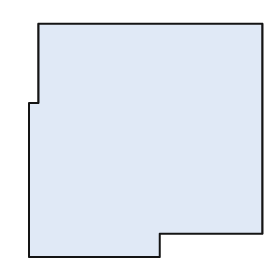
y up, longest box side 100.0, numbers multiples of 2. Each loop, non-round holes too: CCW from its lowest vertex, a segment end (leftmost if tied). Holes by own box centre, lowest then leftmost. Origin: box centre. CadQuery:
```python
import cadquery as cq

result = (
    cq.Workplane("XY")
    .moveTo(-50.0, -50.0)
    .lineTo(6.0, -50.0)
    .lineTo(6.0, -40.0)
    .lineTo(50.0, -40.0)
    .lineTo(50.0, 50.0)
    .lineTo(-46.0, 50.0)
    .lineTo(-46.0, 16.0)
    .lineTo(-50.0, 16.0)
    .close()
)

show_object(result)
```